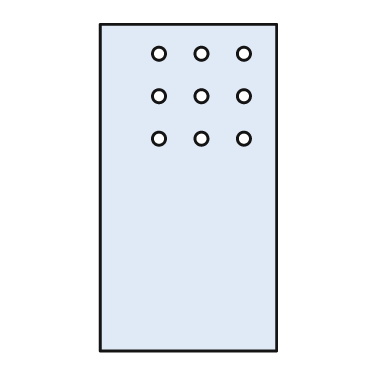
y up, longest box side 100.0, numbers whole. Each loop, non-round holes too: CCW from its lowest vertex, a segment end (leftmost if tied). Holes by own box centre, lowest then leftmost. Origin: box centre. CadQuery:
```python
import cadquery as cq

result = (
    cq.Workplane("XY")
    .moveTo(-27.0, -50.0)
    .lineTo(27.0, -50.0)
    .lineTo(27.0, 50.0)
    .lineTo(-27.0, 50.0)
    .close()
    .moveTo(-9.0, 15.0)
    .circle(2.0)
    .moveTo(4.0, 15.0)
    .circle(2.0)
    .moveTo(17.0, 15.0)
    .circle(2.0)
    .moveTo(-9.0, 28.0)
    .circle(2.0)
    .moveTo(4.0, 28.0)
    .circle(2.0)
    .moveTo(17.0, 28.0)
    .circle(2.0)
    .moveTo(-9.0, 41.0)
    .circle(2.0)
    .moveTo(4.0, 41.0)
    .circle(2.0)
    .moveTo(17.0, 41.0)
    .circle(2.0)
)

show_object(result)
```